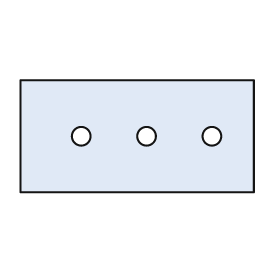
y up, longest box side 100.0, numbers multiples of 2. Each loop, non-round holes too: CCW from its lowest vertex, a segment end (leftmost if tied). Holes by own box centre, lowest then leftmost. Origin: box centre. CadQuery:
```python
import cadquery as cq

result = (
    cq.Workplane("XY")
    .moveTo(-50.0, -24.0)
    .lineTo(50.0, -24.0)
    .lineTo(50.0, 24.0)
    .lineTo(-50.0, 24.0)
    .close()
    .moveTo(-24.0, 0.0)
    .circle(4.0)
    .moveTo(4.0, 0.0)
    .circle(4.0)
    .moveTo(32.0, 0.0)
    .circle(4.0)
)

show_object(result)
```